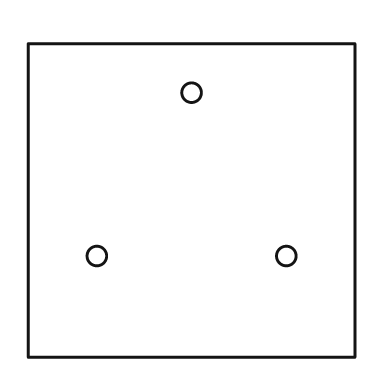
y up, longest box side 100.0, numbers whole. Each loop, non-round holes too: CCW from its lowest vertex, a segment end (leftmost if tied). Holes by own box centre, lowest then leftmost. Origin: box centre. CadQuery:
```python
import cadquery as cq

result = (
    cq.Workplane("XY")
    .moveTo(-50.0, -48.0)
    .lineTo(50.0, -48.0)
    .lineTo(50.0, 48.0)
    .lineTo(-50.0, 48.0)
    .close()
    .moveTo(-29.0, -17.0)
    .circle(3.0)
    .moveTo(29.0, -17.0)
    .circle(3.0)
    .moveTo(0.0, 33.0)
    .circle(3.0)
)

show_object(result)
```